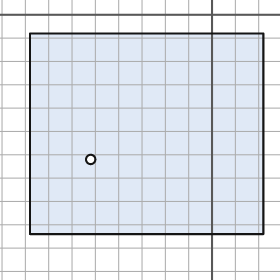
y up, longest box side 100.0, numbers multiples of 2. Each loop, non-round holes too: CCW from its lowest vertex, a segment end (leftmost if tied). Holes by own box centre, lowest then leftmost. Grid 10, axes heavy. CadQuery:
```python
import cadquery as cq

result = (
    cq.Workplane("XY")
    .moveTo(-78.0, -94.0)
    .lineTo(22.0, -94.0)
    .lineTo(22.0, -8.0)
    .lineTo(-78.0, -8.0)
    .close()
    .moveTo(-52.0, -62.0)
    .circle(2.0)
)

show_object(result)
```